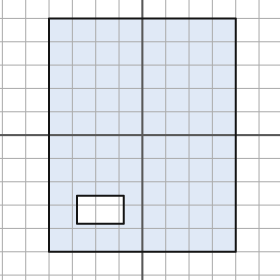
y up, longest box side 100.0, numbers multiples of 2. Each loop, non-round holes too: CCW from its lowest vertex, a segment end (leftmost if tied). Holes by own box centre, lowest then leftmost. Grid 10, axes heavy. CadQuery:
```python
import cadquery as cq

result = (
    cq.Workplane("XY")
    .moveTo(-40.0, -50.0)
    .lineTo(40.0, -50.0)
    .lineTo(40.0, 50.0)
    .lineTo(-40.0, 50.0)
    .close()
    .moveTo(-28.0, -38.0)
    .lineTo(-8.0, -38.0)
    .lineTo(-8.0, -26.0)
    .lineTo(-28.0, -26.0)
    .close()
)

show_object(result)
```